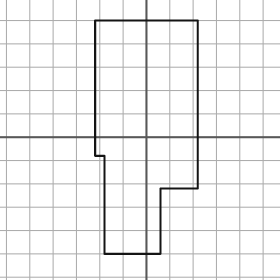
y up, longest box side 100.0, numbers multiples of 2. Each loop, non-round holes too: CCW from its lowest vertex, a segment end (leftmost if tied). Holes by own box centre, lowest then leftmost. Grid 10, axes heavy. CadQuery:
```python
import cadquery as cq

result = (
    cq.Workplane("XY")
    .moveTo(-18.0, -50.0)
    .lineTo(6.0, -50.0)
    .lineTo(6.0, -22.0)
    .lineTo(22.0, -22.0)
    .lineTo(22.0, 50.0)
    .lineTo(-22.0, 50.0)
    .lineTo(-22.0, -8.0)
    .lineTo(-18.0, -8.0)
    .close()
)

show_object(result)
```